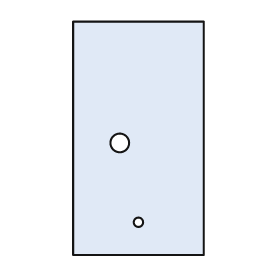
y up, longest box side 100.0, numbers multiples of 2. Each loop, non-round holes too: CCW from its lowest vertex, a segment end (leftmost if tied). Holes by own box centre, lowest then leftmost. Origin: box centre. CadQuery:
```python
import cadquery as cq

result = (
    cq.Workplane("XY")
    .moveTo(-28.0, -50.0)
    .lineTo(28.0, -50.0)
    .lineTo(28.0, 50.0)
    .lineTo(-28.0, 50.0)
    .close()
    .moveTo(0.0, -36.0)
    .circle(2.0)
    .moveTo(-8.0, -2.0)
    .circle(4.0)
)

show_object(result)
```